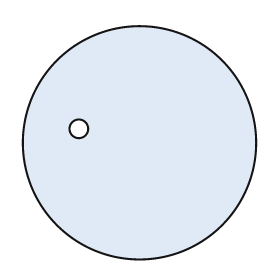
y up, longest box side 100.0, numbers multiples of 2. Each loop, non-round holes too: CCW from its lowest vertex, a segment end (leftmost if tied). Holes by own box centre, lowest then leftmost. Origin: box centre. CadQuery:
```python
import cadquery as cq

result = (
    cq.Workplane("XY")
    .moveTo(0.0, 0.0)
    .circle(50.0)
    .moveTo(-26.0, 6.0)
    .circle(4.0)
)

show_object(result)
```